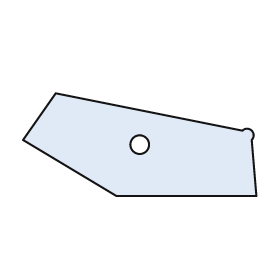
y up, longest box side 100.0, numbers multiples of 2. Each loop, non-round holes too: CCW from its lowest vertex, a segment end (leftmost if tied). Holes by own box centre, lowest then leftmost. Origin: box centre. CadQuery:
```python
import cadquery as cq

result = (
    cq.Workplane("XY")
    .moveTo(-10.0, -22.0)
    .lineTo(50.0, -22.0)
    .lineTo(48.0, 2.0)
    .threePointArc((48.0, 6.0), (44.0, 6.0))
    .lineTo(-36.0, 22.0)
    .lineTo(-50.0, 2.0)
    .close()
    .moveTo(0.0, 0.0)
    .circle(4.0)
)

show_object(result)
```